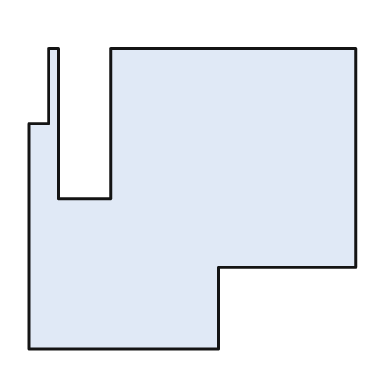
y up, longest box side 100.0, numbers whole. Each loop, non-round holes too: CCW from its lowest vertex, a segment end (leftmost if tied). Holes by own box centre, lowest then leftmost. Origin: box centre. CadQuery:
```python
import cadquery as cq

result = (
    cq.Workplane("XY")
    .moveTo(-50.0, -46.0)
    .lineTo(8.0, -46.0)
    .lineTo(8.0, -21.0)
    .lineTo(50.0, -21.0)
    .lineTo(50.0, 46.0)
    .lineTo(-25.0, 46.0)
    .lineTo(-25.0, 0.0)
    .lineTo(-41.0, 0.0)
    .lineTo(-41.0, 46.0)
    .lineTo(-44.0, 46.0)
    .lineTo(-44.0, 23.0)
    .lineTo(-50.0, 23.0)
    .close()
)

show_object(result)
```